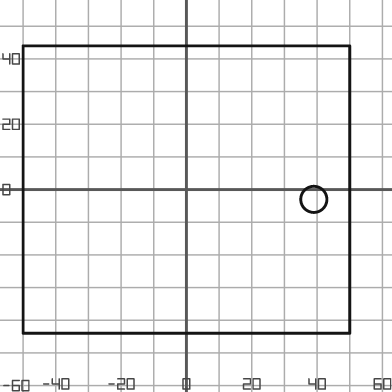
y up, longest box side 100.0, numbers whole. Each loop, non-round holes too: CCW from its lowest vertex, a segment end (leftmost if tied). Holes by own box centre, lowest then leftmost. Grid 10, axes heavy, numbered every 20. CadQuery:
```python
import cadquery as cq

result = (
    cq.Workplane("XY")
    .moveTo(-50.0, -44.0)
    .lineTo(50.0, -44.0)
    .lineTo(50.0, 44.0)
    .lineTo(-50.0, 44.0)
    .close()
    .moveTo(39.0, -3.0)
    .circle(4.0)
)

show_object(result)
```